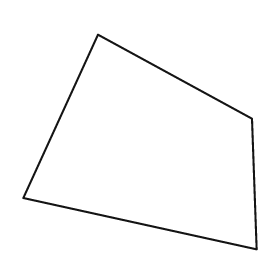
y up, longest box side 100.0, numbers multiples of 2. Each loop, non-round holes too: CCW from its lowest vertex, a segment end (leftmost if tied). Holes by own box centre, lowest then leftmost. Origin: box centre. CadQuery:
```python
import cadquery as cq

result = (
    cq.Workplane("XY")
    .moveTo(50.0, -46.0)
    .lineTo(48.0, 10.0)
    .lineTo(-18.0, 46.0)
    .lineTo(-50.0, -24.0)
    .close()
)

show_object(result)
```